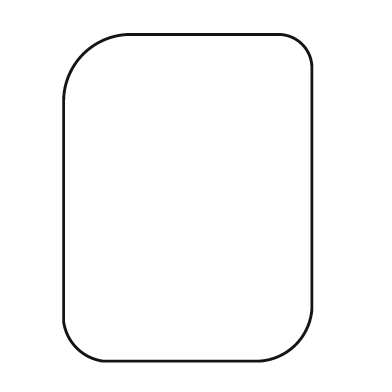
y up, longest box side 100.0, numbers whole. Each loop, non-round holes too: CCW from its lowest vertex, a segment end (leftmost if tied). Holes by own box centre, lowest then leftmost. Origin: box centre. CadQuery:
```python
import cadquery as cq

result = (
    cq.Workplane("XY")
    .moveTo(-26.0, -50.0)
    .lineTo(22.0, -50.0)
    .threePointArc((33.0, -45.0), (38.0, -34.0))
    .lineTo(38.0, 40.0)
    .threePointArc((35.0, 47.0), (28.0, 50.0))
    .lineTo(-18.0, 50.0)
    .threePointArc((-32.0, 44.0), (-38.0, 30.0))
    .lineTo(-38.0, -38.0)
    .threePointArc((-34.0, -46.0), (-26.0, -50.0))
    .close()
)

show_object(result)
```